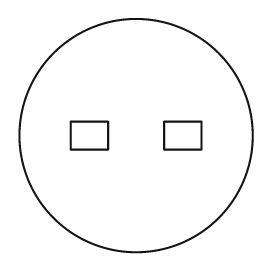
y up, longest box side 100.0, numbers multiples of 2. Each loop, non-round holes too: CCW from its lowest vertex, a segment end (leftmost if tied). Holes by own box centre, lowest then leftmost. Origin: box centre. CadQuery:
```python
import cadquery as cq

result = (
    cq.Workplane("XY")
    .moveTo(0.0, 0.0)
    .circle(50.0)
    .moveTo(-28.0, -6.0)
    .lineTo(-12.0, -6.0)
    .lineTo(-12.0, 6.0)
    .lineTo(-28.0, 6.0)
    .close()
    .moveTo(12.0, -6.0)
    .lineTo(28.0, -6.0)
    .lineTo(28.0, 6.0)
    .lineTo(12.0, 6.0)
    .close()
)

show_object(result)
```